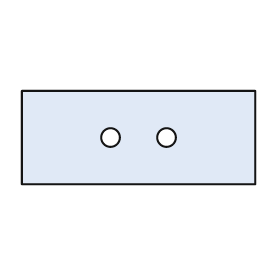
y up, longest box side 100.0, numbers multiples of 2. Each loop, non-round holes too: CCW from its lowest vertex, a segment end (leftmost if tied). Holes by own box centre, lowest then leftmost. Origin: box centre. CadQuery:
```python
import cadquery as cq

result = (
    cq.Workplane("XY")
    .moveTo(-50.0, -20.0)
    .lineTo(50.0, -20.0)
    .lineTo(50.0, 20.0)
    .lineTo(-50.0, 20.0)
    .close()
    .moveTo(-12.0, 0.0)
    .circle(4.0)
    .moveTo(12.0, 0.0)
    .circle(4.0)
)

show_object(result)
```